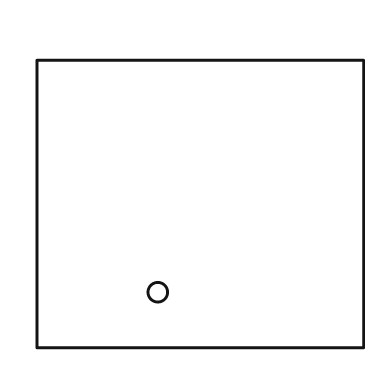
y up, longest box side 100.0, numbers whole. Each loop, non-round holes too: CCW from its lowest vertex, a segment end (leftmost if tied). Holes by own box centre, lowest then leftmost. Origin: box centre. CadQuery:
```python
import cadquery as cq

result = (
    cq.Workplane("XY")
    .moveTo(-50.0, -44.0)
    .lineTo(50.0, -44.0)
    .lineTo(50.0, 44.0)
    .lineTo(-50.0, 44.0)
    .close()
    .moveTo(-13.0, -27.0)
    .circle(3.0)
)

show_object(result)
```